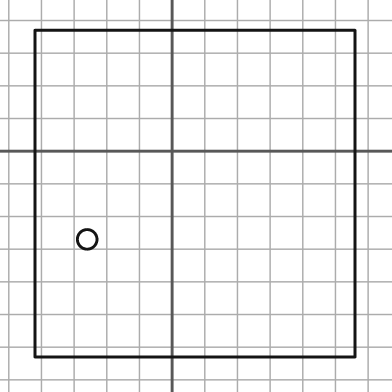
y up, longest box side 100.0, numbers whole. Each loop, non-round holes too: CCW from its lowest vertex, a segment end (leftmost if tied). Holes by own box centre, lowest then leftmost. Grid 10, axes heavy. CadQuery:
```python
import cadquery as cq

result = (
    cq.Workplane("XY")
    .moveTo(-42.0, -63.0)
    .lineTo(56.0, -63.0)
    .lineTo(56.0, 37.0)
    .lineTo(-42.0, 37.0)
    .close()
    .moveTo(-26.0, -27.0)
    .circle(3.0)
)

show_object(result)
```